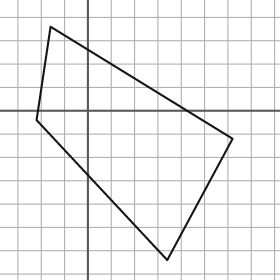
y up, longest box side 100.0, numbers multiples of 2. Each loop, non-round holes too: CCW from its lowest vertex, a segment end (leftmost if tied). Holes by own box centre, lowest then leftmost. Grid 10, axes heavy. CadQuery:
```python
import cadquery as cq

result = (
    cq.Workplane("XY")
    .moveTo(34.0, -64.0)
    .lineTo(62.0, -12.0)
    .lineTo(-16.0, 36.0)
    .lineTo(-22.0, -4.0)
    .close()
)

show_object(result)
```